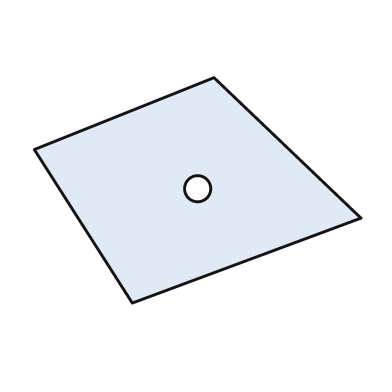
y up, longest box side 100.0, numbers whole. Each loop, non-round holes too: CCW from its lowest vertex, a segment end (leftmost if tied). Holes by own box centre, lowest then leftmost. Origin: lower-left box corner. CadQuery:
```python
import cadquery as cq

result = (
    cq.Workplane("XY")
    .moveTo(30.0, 0.0)
    .lineTo(100.0, 26.0)
    .lineTo(55.0, 69.0)
    .lineTo(0.0, 47.0)
    .close()
    .moveTo(50.0, 35.0)
    .circle(4.0)
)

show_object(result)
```